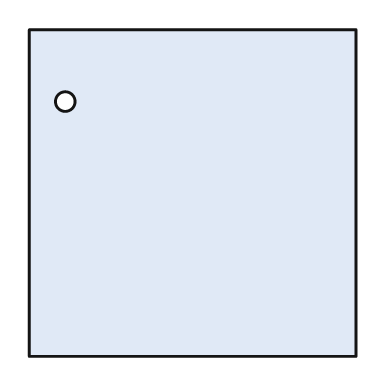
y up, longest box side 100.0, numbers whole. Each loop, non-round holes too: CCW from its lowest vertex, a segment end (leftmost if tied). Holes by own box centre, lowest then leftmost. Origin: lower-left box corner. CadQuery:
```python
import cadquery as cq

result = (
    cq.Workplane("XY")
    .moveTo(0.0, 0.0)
    .lineTo(100.0, 0.0)
    .lineTo(100.0, 100.0)
    .lineTo(0.0, 100.0)
    .close()
    .moveTo(11.0, 78.0)
    .circle(3.0)
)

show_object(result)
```